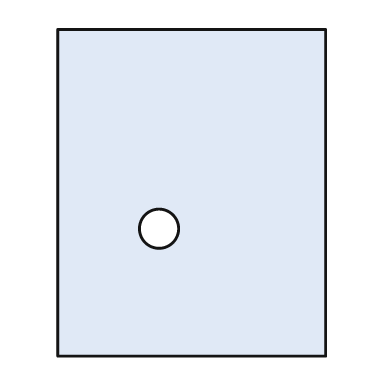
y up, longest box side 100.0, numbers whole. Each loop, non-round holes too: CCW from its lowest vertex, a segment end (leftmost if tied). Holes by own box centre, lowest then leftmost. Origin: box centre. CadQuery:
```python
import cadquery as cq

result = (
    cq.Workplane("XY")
    .moveTo(-41.0, -50.0)
    .lineTo(41.0, -50.0)
    .lineTo(41.0, 50.0)
    .lineTo(-41.0, 50.0)
    .close()
    .moveTo(-10.0, -11.0)
    .circle(6.0)
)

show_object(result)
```